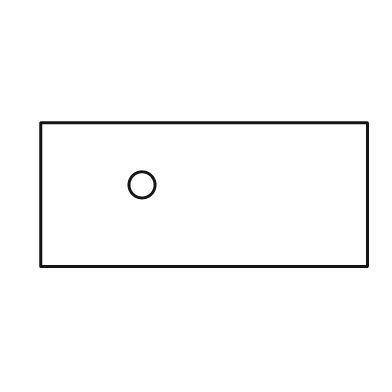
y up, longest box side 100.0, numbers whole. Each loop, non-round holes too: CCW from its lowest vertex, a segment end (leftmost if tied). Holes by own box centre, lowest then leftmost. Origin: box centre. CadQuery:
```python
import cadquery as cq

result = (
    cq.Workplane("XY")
    .moveTo(-50.0, -22.0)
    .lineTo(50.0, -22.0)
    .lineTo(50.0, 22.0)
    .lineTo(-50.0, 22.0)
    .close()
    .moveTo(-19.0, 3.0)
    .circle(4.0)
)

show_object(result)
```